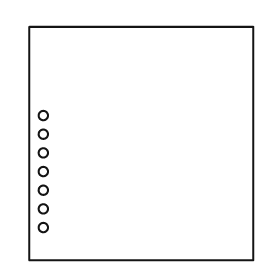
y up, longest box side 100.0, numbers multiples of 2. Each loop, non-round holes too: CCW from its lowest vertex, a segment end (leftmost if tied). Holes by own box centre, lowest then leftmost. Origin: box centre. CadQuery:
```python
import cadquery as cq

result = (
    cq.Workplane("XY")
    .moveTo(-48.0, -50.0)
    .lineTo(48.0, -50.0)
    .lineTo(48.0, 50.0)
    .lineTo(-48.0, 50.0)
    .close()
    .moveTo(-42.0, -36.0)
    .circle(2.0)
    .moveTo(-42.0, -28.0)
    .circle(2.0)
    .moveTo(-42.0, -20.0)
    .circle(2.0)
    .moveTo(-42.0, -12.0)
    .circle(2.0)
    .moveTo(-42.0, -4.0)
    .circle(2.0)
    .moveTo(-42.0, 4.0)
    .circle(2.0)
    .moveTo(-42.0, 12.0)
    .circle(2.0)
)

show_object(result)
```